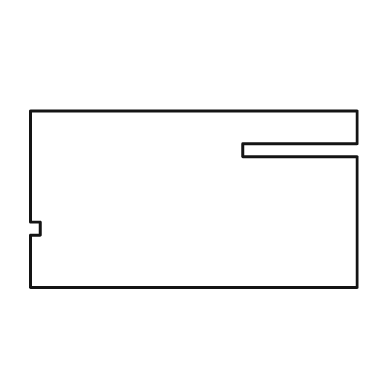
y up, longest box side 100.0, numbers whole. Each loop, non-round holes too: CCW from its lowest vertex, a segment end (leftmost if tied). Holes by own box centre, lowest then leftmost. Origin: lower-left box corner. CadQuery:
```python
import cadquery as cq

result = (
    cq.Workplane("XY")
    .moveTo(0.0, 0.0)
    .lineTo(100.0, 0.0)
    .lineTo(100.0, 40.0)
    .lineTo(65.0, 40.0)
    .lineTo(65.0, 44.0)
    .lineTo(100.0, 44.0)
    .lineTo(100.0, 54.0)
    .lineTo(0.0, 54.0)
    .lineTo(0.0, 20.0)
    .lineTo(3.0, 20.0)
    .lineTo(3.0, 16.0)
    .lineTo(0.0, 16.0)
    .close()
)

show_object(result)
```